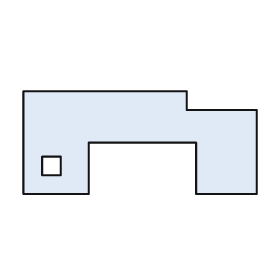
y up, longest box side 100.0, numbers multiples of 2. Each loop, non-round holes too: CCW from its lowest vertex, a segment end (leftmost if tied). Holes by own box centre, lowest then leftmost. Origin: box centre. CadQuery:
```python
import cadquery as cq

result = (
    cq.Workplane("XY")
    .moveTo(-50.0, -22.0)
    .lineTo(-22.0, -22.0)
    .lineTo(-22.0, 0.0)
    .lineTo(24.0, 0.0)
    .lineTo(24.0, -22.0)
    .lineTo(50.0, -22.0)
    .lineTo(50.0, 14.0)
    .lineTo(20.0, 14.0)
    .lineTo(20.0, 22.0)
    .lineTo(-50.0, 22.0)
    .close()
    .moveTo(-42.0, -14.0)
    .lineTo(-34.0, -14.0)
    .lineTo(-34.0, -6.0)
    .lineTo(-42.0, -6.0)
    .close()
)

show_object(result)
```